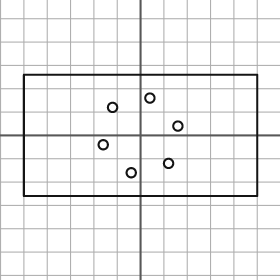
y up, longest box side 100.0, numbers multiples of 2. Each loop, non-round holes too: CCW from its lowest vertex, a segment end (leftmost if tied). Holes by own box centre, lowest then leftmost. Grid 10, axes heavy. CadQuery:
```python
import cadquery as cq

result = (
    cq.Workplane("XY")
    .moveTo(-50.0, -26.0)
    .lineTo(50.0, -26.0)
    .lineTo(50.0, 26.0)
    .lineTo(-50.0, 26.0)
    .close()
    .moveTo(-4.0, -16.0)
    .circle(2.0)
    .moveTo(12.0, -12.0)
    .circle(2.0)
    .moveTo(-16.0, -4.0)
    .circle(2.0)
    .moveTo(16.0, 4.0)
    .circle(2.0)
    .moveTo(-12.0, 12.0)
    .circle(2.0)
    .moveTo(4.0, 16.0)
    .circle(2.0)
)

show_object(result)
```